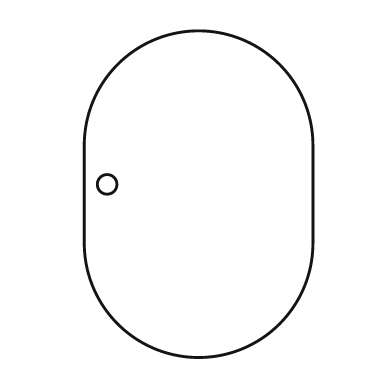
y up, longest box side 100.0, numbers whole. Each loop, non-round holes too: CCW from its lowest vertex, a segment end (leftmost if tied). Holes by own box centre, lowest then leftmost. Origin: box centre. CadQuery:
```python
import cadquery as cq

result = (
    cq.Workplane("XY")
    .moveTo(-35.0, -15.0)
    .threePointArc((0.0, -50.0), (35.0, -15.0))
    .lineTo(35.0, 15.0)
    .threePointArc((0.0, 50.0), (-35.0, 15.0))
    .close()
    .moveTo(-28.0, 3.0)
    .circle(3.0)
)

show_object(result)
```